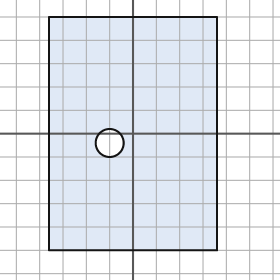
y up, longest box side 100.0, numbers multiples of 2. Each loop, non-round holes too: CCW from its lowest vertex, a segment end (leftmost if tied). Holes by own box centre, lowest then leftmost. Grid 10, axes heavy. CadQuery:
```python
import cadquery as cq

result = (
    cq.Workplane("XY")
    .moveTo(-36.0, -50.0)
    .lineTo(36.0, -50.0)
    .lineTo(36.0, 50.0)
    .lineTo(-36.0, 50.0)
    .close()
    .moveTo(-10.0, -4.0)
    .circle(6.0)
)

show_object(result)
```